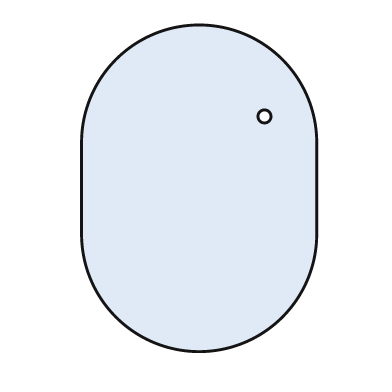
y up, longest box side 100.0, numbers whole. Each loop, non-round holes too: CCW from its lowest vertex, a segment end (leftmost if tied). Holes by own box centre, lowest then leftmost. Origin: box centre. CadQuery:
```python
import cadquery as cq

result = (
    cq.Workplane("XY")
    .moveTo(-36.0, -14.0)
    .threePointArc((0.0, -50.0), (36.0, -14.0))
    .lineTo(36.0, 14.0)
    .threePointArc((0.0, 50.0), (-36.0, 14.0))
    .close()
    .moveTo(20.0, 22.0)
    .circle(2.0)
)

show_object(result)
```